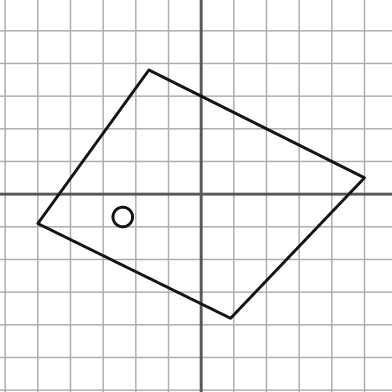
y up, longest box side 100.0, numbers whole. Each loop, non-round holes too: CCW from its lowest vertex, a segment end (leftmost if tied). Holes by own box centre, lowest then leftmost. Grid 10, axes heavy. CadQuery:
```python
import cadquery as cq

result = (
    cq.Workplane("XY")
    .moveTo(9.0, -38.0)
    .lineTo(50.0, 5.0)
    .lineTo(-16.0, 38.0)
    .lineTo(-50.0, -9.0)
    .close()
    .moveTo(-24.0, -7.0)
    .circle(3.0)
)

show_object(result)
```